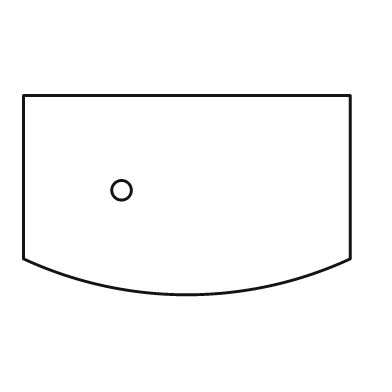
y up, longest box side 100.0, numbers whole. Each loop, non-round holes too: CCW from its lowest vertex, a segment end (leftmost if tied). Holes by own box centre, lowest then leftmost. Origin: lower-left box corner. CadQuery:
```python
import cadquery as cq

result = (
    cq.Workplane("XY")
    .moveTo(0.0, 11.0)
    .threePointArc((50.0, 0.0), (100.0, 11.0))
    .lineTo(100.0, 61.0)
    .lineTo(0.0, 61.0)
    .close()
    .moveTo(30.0, 32.0)
    .circle(3.0)
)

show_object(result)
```